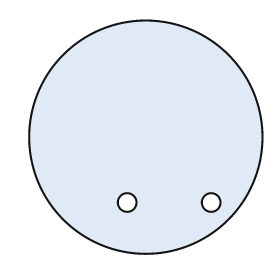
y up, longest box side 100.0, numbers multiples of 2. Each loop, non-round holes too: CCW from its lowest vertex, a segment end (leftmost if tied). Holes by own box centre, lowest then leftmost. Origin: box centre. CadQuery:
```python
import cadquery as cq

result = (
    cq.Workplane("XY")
    .moveTo(0.0, 0.0)
    .circle(50.0)
    .moveTo(-8.0, -28.0)
    .circle(4.0)
    .moveTo(28.0, -28.0)
    .circle(4.0)
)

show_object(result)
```